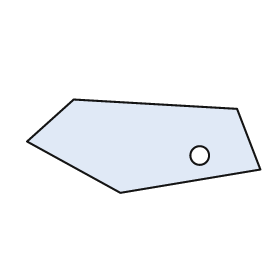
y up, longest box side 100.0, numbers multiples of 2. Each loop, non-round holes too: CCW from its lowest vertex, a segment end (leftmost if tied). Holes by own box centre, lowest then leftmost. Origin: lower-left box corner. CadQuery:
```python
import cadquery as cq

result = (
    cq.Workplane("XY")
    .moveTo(40.0, 0.0)
    .lineTo(100.0, 10.0)
    .lineTo(90.0, 36.0)
    .lineTo(20.0, 40.0)
    .lineTo(0.0, 22.0)
    .close()
    .moveTo(74.0, 16.0)
    .circle(4.0)
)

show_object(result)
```